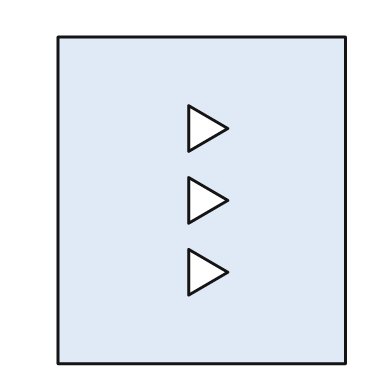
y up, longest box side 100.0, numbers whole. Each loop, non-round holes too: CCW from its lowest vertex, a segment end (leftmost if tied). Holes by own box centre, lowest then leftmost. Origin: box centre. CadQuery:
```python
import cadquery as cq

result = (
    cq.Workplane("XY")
    .moveTo(-44.0, -50.0)
    .lineTo(44.0, -50.0)
    .lineTo(44.0, 50.0)
    .lineTo(-44.0, 50.0)
    .close()
    .moveTo(-4.0, -29.0)
    .lineTo(8.0, -22.0)
    .lineTo(-4.0, -15.0)
    .close()
    .moveTo(-4.0, -7.0)
    .lineTo(8.0, 0.0)
    .lineTo(-4.0, 7.0)
    .close()
    .moveTo(-4.0, 15.0)
    .lineTo(8.0, 22.0)
    .lineTo(-4.0, 29.0)
    .close()
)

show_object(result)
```